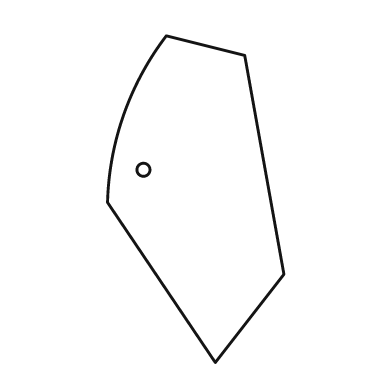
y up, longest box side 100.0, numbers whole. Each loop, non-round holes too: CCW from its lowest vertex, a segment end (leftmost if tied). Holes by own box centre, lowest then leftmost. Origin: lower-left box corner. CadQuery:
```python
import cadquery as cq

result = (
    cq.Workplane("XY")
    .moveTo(33.0, 0.0)
    .lineTo(54.0, 27.0)
    .lineTo(42.0, 94.0)
    .lineTo(18.0, 100.0)
    .threePointArc((5.0, 76.0), (0.0, 49.0))
    .close()
    .moveTo(11.0, 59.0)
    .circle(2.0)
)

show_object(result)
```